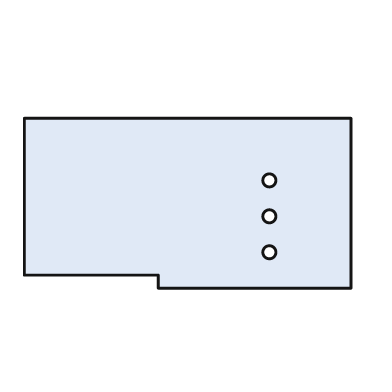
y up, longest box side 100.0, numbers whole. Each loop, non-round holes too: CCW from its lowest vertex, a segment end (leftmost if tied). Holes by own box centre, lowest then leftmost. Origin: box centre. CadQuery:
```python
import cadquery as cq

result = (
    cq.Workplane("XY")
    .moveTo(-9.0, -26.0)
    .lineTo(50.0, -26.0)
    .lineTo(50.0, 26.0)
    .lineTo(-50.0, 26.0)
    .lineTo(-50.0, -22.0)
    .lineTo(-9.0, -22.0)
    .close()
    .moveTo(25.0, -15.0)
    .circle(2.0)
    .moveTo(25.0, -4.0)
    .circle(2.0)
    .moveTo(25.0, 7.0)
    .circle(2.0)
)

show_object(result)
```